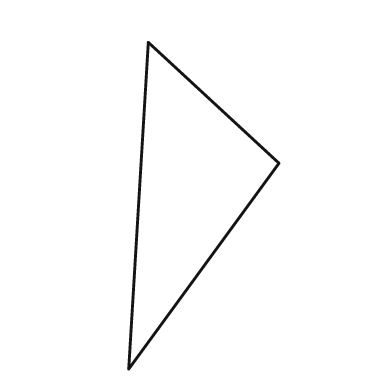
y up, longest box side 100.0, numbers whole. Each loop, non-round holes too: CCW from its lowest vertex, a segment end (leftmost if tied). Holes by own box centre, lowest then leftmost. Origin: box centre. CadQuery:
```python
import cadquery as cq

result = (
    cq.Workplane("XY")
    .moveTo(-23.0, -50.0)
    .lineTo(23.0, 13.0)
    .lineTo(-17.0, 50.0)
    .close()
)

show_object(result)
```